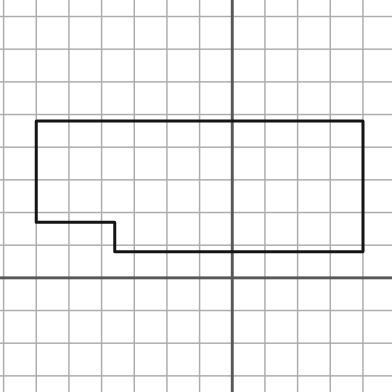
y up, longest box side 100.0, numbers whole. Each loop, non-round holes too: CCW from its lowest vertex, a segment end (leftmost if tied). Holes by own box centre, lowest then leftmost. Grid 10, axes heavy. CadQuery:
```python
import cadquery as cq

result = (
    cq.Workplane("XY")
    .moveTo(-36.0, 8.0)
    .lineTo(40.0, 8.0)
    .lineTo(40.0, 48.0)
    .lineTo(-60.0, 48.0)
    .lineTo(-60.0, 17.0)
    .lineTo(-36.0, 17.0)
    .close()
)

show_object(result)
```